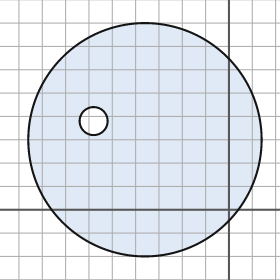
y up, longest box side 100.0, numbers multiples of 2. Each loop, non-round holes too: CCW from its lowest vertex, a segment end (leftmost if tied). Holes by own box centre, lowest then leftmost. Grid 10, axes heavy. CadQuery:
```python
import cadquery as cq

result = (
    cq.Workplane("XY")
    .moveTo(-36.0, 30.0)
    .circle(50.0)
    .moveTo(-58.0, 38.0)
    .circle(6.0)
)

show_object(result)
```